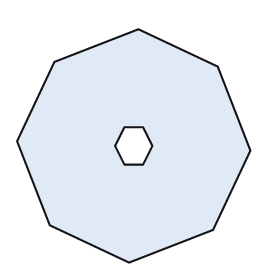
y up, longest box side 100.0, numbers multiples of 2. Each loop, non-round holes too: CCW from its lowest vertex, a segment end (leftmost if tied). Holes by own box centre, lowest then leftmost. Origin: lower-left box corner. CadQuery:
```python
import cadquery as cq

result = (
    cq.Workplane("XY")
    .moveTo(48.0, 0.0)
    .lineTo(84.0, 14.0)
    .lineTo(100.0, 48.0)
    .lineTo(86.0, 84.0)
    .lineTo(52.0, 100.0)
    .lineTo(16.0, 86.0)
    .lineTo(0.0, 52.0)
    .lineTo(14.0, 16.0)
    .close()
    .moveTo(46.0, 42.0)
    .lineTo(54.0, 42.0)
    .lineTo(58.0, 50.0)
    .lineTo(54.0, 58.0)
    .lineTo(46.0, 58.0)
    .lineTo(42.0, 50.0)
    .close()
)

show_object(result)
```